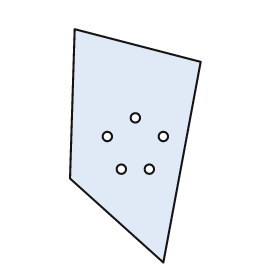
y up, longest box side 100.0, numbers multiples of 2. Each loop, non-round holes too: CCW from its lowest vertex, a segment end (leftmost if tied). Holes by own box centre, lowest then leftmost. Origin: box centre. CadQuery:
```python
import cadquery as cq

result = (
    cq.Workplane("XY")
    .moveTo(12.0, -50.0)
    .lineTo(28.0, 36.0)
    .lineTo(-26.0, 50.0)
    .lineTo(-28.0, -14.0)
    .close()
    .moveTo(-6.0, -10.0)
    .circle(2.0)
    .moveTo(6.0, -10.0)
    .circle(2.0)
    .moveTo(-12.0, 4.0)
    .circle(2.0)
    .moveTo(12.0, 4.0)
    .circle(2.0)
    .moveTo(0.0, 12.0)
    .circle(2.0)
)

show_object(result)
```